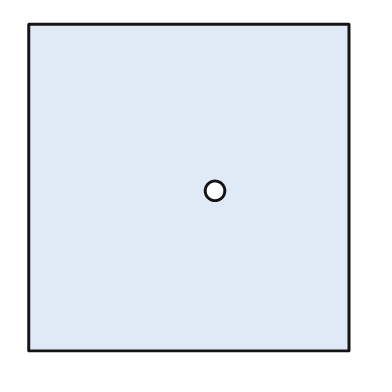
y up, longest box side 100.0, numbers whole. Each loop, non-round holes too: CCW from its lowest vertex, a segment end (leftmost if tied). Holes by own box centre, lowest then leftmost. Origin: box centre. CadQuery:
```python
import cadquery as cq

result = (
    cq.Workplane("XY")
    .moveTo(-49.0, -50.0)
    .lineTo(49.0, -50.0)
    .lineTo(49.0, 50.0)
    .lineTo(-49.0, 50.0)
    .close()
    .moveTo(8.0, -1.0)
    .circle(3.0)
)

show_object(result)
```